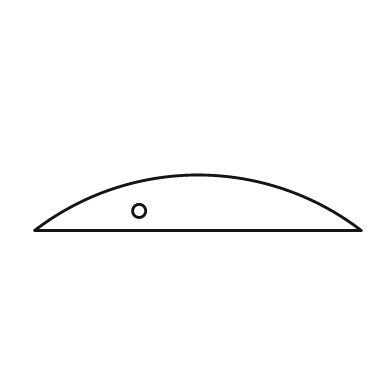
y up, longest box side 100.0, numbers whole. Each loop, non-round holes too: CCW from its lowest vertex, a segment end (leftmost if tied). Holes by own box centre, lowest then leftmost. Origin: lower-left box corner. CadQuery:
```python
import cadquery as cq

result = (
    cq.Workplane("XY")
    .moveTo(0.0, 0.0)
    .lineTo(100.0, 0.0)
    .threePointArc((50.0, 17.0), (0.0, 0.0))
    .close()
    .moveTo(32.0, 6.0)
    .circle(2.0)
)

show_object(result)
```